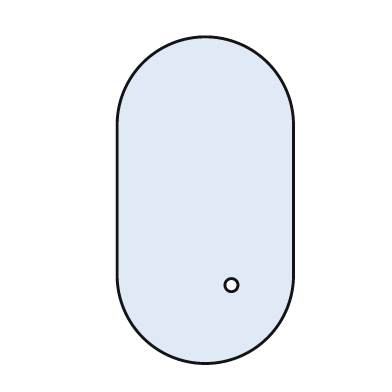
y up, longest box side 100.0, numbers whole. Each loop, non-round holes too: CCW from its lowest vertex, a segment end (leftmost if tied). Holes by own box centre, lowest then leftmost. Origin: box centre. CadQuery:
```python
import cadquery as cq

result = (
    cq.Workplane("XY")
    .moveTo(-27.0, -23.0)
    .threePointArc((0.0, -50.0), (27.0, -23.0))
    .lineTo(27.0, 23.0)
    .threePointArc((0.0, 50.0), (-27.0, 23.0))
    .close()
    .moveTo(8.0, -26.0)
    .circle(2.0)
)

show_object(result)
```